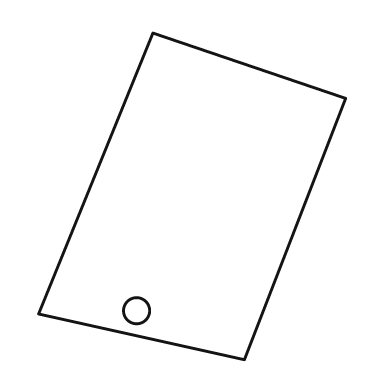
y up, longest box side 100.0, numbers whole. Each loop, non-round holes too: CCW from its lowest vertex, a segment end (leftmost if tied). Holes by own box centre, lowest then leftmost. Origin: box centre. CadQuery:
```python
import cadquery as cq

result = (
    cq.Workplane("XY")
    .moveTo(16.0, -50.0)
    .lineTo(47.0, 30.0)
    .lineTo(-12.0, 50.0)
    .lineTo(-47.0, -36.0)
    .close()
    .moveTo(-17.0, -35.0)
    .circle(4.0)
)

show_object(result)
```